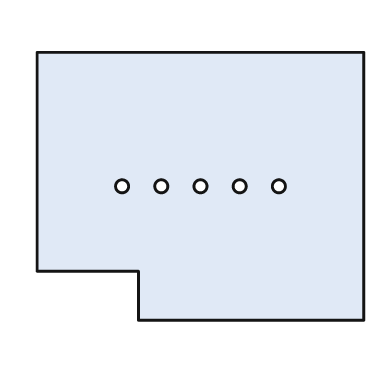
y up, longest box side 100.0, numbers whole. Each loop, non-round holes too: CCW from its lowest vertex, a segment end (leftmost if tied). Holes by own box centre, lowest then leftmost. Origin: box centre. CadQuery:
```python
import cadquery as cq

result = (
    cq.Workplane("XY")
    .moveTo(-19.0, -41.0)
    .lineTo(50.0, -41.0)
    .lineTo(50.0, 41.0)
    .lineTo(-50.0, 41.0)
    .lineTo(-50.0, -26.0)
    .lineTo(-19.0, -26.0)
    .close()
    .moveTo(-24.0, 0.0)
    .circle(2.0)
    .moveTo(-12.0, 0.0)
    .circle(2.0)
    .moveTo(0.0, 0.0)
    .circle(2.0)
    .moveTo(12.0, 0.0)
    .circle(2.0)
    .moveTo(24.0, 0.0)
    .circle(2.0)
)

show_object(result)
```